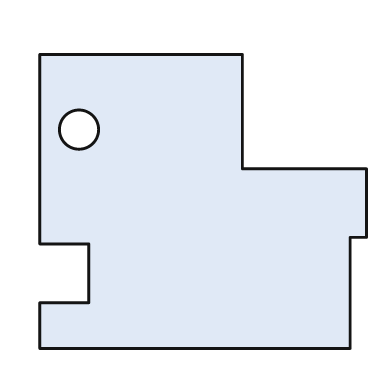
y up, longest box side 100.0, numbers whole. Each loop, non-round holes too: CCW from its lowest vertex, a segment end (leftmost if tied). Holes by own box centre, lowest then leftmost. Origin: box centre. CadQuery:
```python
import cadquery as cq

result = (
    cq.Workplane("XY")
    .moveTo(-50.0, -45.0)
    .lineTo(45.0, -45.0)
    .lineTo(45.0, -11.0)
    .lineTo(50.0, -11.0)
    .lineTo(50.0, 10.0)
    .lineTo(12.0, 10.0)
    .lineTo(12.0, 45.0)
    .lineTo(-50.0, 45.0)
    .lineTo(-50.0, -13.0)
    .lineTo(-35.0, -13.0)
    .lineTo(-35.0, -31.0)
    .lineTo(-50.0, -31.0)
    .close()
    .moveTo(-38.0, 22.0)
    .circle(6.0)
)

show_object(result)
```